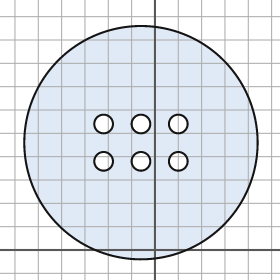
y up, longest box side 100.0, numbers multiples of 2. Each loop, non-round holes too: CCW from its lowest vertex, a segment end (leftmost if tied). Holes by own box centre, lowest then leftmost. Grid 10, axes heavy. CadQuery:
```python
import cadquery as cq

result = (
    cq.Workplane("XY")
    .moveTo(-6.0, 46.0)
    .circle(50.0)
    .moveTo(-22.0, 38.0)
    .circle(4.0)
    .moveTo(-6.0, 38.0)
    .circle(4.0)
    .moveTo(10.0, 38.0)
    .circle(4.0)
    .moveTo(-22.0, 54.0)
    .circle(4.0)
    .moveTo(-6.0, 54.0)
    .circle(4.0)
    .moveTo(10.0, 54.0)
    .circle(4.0)
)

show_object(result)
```